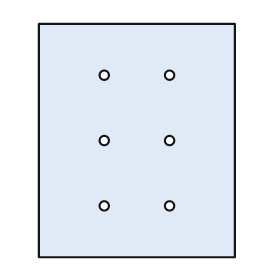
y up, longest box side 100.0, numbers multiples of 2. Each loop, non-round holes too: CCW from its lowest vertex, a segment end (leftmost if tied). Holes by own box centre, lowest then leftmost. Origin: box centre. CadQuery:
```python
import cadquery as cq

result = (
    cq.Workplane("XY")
    .moveTo(-42.0, -50.0)
    .lineTo(42.0, -50.0)
    .lineTo(42.0, 50.0)
    .lineTo(-42.0, 50.0)
    .close()
    .moveTo(-14.0, -28.0)
    .circle(2.0)
    .moveTo(14.0, -28.0)
    .circle(2.0)
    .moveTo(-14.0, 0.0)
    .circle(2.0)
    .moveTo(14.0, 0.0)
    .circle(2.0)
    .moveTo(-14.0, 28.0)
    .circle(2.0)
    .moveTo(14.0, 28.0)
    .circle(2.0)
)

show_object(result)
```